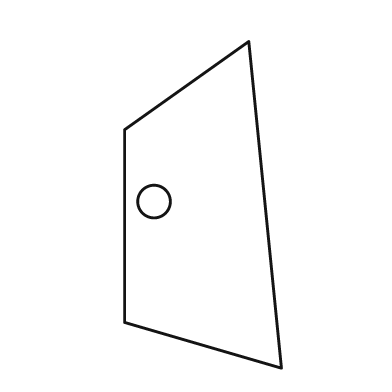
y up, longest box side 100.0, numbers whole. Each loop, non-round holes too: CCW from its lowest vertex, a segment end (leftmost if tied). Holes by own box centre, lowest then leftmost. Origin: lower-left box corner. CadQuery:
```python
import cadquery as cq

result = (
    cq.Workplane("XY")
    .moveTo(48.0, 0.0)
    .lineTo(38.0, 100.0)
    .lineTo(0.0, 73.0)
    .lineTo(0.0, 14.0)
    .close()
    .moveTo(9.0, 51.0)
    .circle(5.0)
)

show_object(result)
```